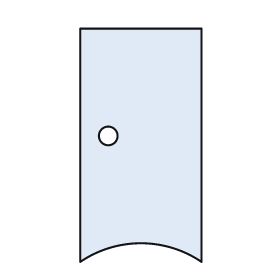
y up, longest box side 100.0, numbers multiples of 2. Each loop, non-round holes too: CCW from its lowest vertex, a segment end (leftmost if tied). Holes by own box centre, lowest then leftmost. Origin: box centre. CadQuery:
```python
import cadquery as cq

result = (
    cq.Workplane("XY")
    .moveTo(-26.0, -50.0)
    .threePointArc((0.0, -42.0), (26.0, -50.0))
    .lineTo(26.0, 50.0)
    .lineTo(-26.0, 50.0)
    .close()
    .moveTo(-14.0, 4.0)
    .circle(4.0)
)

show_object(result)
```